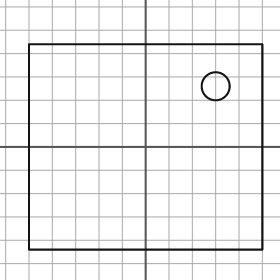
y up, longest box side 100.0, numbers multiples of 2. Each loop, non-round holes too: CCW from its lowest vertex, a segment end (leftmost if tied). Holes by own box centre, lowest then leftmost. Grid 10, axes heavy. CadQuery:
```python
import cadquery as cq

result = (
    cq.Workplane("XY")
    .moveTo(-50.0, -44.0)
    .lineTo(50.0, -44.0)
    .lineTo(50.0, 44.0)
    .lineTo(-50.0, 44.0)
    .close()
    .moveTo(30.0, 26.0)
    .circle(6.0)
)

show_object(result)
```